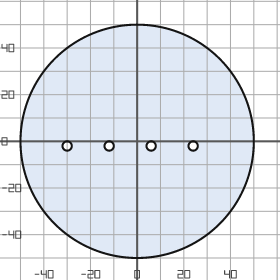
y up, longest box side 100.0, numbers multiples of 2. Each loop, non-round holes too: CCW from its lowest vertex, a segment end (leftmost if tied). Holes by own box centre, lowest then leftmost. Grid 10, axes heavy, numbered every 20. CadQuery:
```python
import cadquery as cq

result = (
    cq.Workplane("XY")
    .moveTo(0.0, 0.0)
    .circle(50.0)
    .moveTo(-30.0, -2.0)
    .circle(2.0)
    .moveTo(-12.0, -2.0)
    .circle(2.0)
    .moveTo(6.0, -2.0)
    .circle(2.0)
    .moveTo(24.0, -2.0)
    .circle(2.0)
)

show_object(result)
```